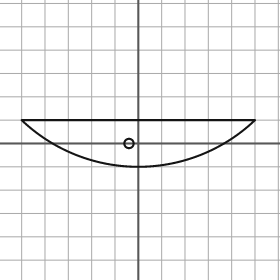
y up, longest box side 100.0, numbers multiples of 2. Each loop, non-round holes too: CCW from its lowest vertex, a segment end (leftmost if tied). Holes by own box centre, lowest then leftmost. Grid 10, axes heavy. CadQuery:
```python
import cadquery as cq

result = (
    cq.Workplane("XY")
    .moveTo(-50.0, 10.0)
    .threePointArc((0.0, -10.0), (50.0, 10.0))
    .close()
    .moveTo(-4.0, 0.0)
    .circle(2.0)
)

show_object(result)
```